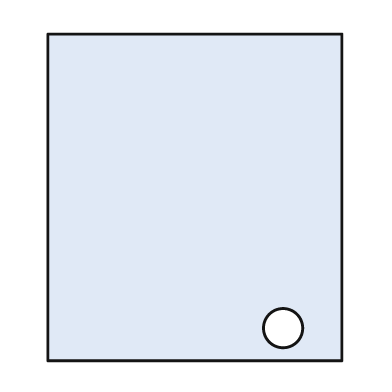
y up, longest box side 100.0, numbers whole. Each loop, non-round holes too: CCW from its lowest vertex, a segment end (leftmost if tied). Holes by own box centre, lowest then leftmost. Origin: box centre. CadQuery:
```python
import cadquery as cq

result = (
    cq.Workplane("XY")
    .moveTo(-45.0, -50.0)
    .lineTo(45.0, -50.0)
    .lineTo(45.0, 50.0)
    .lineTo(-45.0, 50.0)
    .close()
    .moveTo(27.0, -40.0)
    .circle(6.0)
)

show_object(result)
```